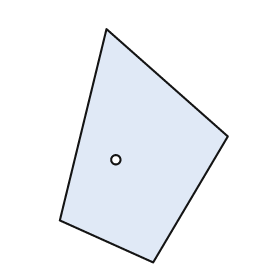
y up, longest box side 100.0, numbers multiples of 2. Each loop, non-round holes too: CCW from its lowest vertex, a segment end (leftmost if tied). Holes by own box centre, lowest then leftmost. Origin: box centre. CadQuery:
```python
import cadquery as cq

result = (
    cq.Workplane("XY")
    .moveTo(4.0, -50.0)
    .lineTo(36.0, 4.0)
    .lineTo(-16.0, 50.0)
    .lineTo(-36.0, -32.0)
    .close()
    .moveTo(-12.0, -6.0)
    .circle(2.0)
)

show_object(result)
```